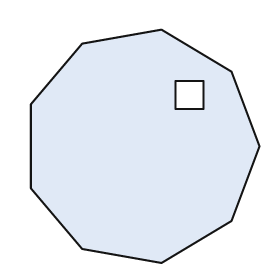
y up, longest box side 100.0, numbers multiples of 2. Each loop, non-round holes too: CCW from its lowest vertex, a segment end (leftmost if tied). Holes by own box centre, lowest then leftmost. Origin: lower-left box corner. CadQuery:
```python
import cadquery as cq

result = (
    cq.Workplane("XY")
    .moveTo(56.0, 0.0)
    .lineTo(86.0, 18.0)
    .lineTo(98.0, 50.0)
    .lineTo(86.0, 82.0)
    .lineTo(56.0, 100.0)
    .lineTo(22.0, 94.0)
    .lineTo(0.0, 68.0)
    .lineTo(0.0, 32.0)
    .lineTo(22.0, 6.0)
    .close()
    .moveTo(62.0, 66.0)
    .lineTo(74.0, 66.0)
    .lineTo(74.0, 78.0)
    .lineTo(62.0, 78.0)
    .close()
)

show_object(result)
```